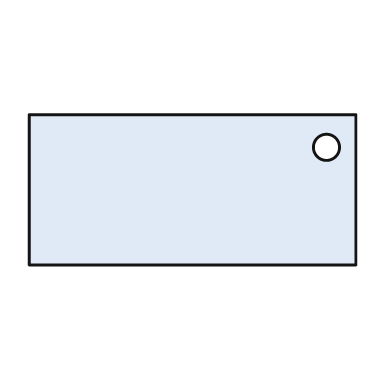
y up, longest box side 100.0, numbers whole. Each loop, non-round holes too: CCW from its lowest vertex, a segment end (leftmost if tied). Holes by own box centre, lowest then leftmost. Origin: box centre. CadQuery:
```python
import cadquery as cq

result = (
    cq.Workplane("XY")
    .moveTo(-50.0, -23.0)
    .lineTo(50.0, -23.0)
    .lineTo(50.0, 23.0)
    .lineTo(-50.0, 23.0)
    .close()
    .moveTo(41.0, 13.0)
    .circle(4.0)
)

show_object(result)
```